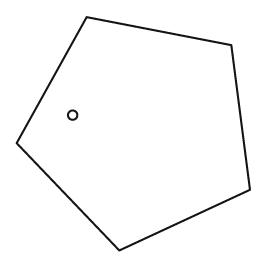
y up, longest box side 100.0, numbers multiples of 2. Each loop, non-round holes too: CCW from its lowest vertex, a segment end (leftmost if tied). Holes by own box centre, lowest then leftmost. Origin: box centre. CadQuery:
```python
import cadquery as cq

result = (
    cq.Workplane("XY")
    .moveTo(-6.0, -50.0)
    .lineTo(50.0, -24.0)
    .lineTo(42.0, 38.0)
    .lineTo(-20.0, 50.0)
    .lineTo(-50.0, -4.0)
    .close()
    .moveTo(-26.0, 8.0)
    .circle(2.0)
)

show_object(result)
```